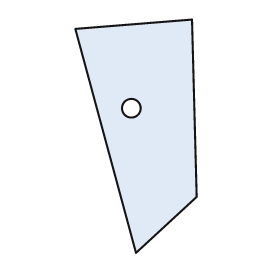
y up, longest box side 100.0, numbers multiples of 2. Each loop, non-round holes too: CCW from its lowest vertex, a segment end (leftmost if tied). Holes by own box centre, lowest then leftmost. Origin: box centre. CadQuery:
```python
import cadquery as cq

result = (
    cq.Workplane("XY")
    .moveTo(0.0, -50.0)
    .lineTo(26.0, -26.0)
    .lineTo(24.0, 50.0)
    .lineTo(-26.0, 46.0)
    .close()
    .moveTo(-2.0, 12.0)
    .circle(4.0)
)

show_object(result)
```